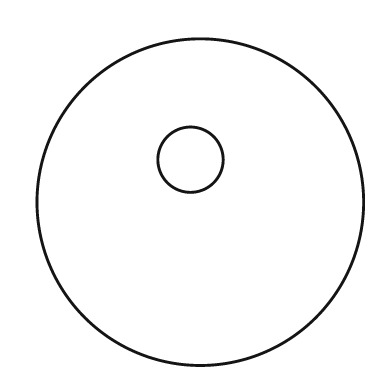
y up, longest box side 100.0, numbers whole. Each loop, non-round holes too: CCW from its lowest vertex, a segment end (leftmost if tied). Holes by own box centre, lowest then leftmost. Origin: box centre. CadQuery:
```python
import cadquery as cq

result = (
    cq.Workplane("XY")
    .moveTo(0.0, 0.0)
    .circle(50.0)
    .moveTo(-3.0, 13.0)
    .circle(10.0)
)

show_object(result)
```